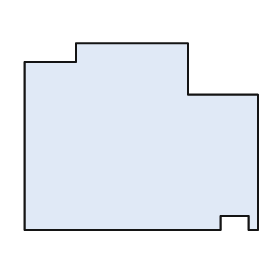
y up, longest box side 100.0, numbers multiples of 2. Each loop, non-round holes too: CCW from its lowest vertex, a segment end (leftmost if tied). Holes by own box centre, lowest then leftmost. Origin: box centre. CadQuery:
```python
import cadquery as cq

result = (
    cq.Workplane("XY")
    .moveTo(-50.0, -40.0)
    .lineTo(34.0, -40.0)
    .lineTo(34.0, -34.0)
    .lineTo(46.0, -34.0)
    .lineTo(46.0, -40.0)
    .lineTo(50.0, -40.0)
    .lineTo(50.0, 18.0)
    .lineTo(20.0, 18.0)
    .lineTo(20.0, 40.0)
    .lineTo(-28.0, 40.0)
    .lineTo(-28.0, 32.0)
    .lineTo(-50.0, 32.0)
    .close()
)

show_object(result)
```